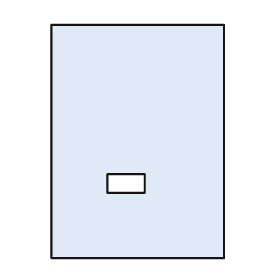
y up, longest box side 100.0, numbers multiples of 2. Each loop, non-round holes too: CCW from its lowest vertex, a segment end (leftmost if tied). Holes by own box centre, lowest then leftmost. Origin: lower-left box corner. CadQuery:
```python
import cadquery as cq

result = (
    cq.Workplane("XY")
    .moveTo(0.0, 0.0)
    .lineTo(74.0, 0.0)
    .lineTo(74.0, 100.0)
    .lineTo(0.0, 100.0)
    .close()
    .moveTo(24.0, 28.0)
    .lineTo(40.0, 28.0)
    .lineTo(40.0, 36.0)
    .lineTo(24.0, 36.0)
    .close()
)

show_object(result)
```